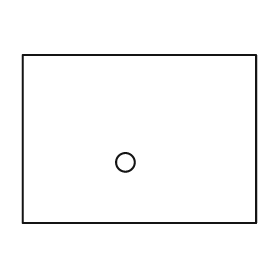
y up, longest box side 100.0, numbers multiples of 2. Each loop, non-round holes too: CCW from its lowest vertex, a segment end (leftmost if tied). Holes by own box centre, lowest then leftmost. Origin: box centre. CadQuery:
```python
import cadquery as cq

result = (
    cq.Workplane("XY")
    .moveTo(-50.0, -36.0)
    .lineTo(50.0, -36.0)
    .lineTo(50.0, 36.0)
    .lineTo(-50.0, 36.0)
    .close()
    .moveTo(-6.0, -10.0)
    .circle(4.0)
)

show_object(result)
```